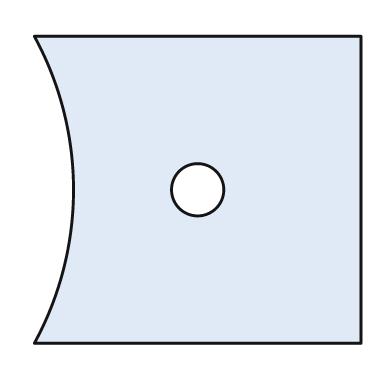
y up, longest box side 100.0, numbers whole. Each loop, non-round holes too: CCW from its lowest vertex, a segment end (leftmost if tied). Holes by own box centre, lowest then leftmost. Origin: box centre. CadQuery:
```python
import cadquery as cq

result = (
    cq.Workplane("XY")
    .moveTo(-50.0, -47.0)
    .lineTo(50.0, -47.0)
    .lineTo(50.0, 47.0)
    .lineTo(-50.0, 47.0)
    .threePointArc((-38.0, 0.0), (-50.0, -47.0))
    .close()
    .moveTo(0.0, 0.0)
    .circle(8.0)
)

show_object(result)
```